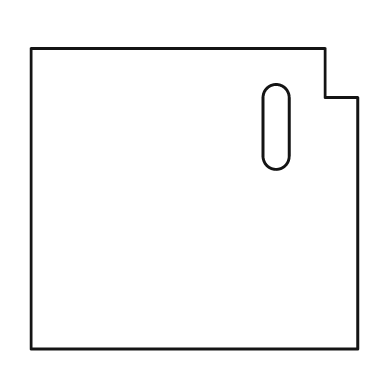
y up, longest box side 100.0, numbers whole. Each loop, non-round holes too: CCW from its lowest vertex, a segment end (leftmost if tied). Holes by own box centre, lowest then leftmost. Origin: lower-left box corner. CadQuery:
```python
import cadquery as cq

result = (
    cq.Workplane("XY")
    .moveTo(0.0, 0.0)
    .lineTo(100.0, 0.0)
    .lineTo(100.0, 77.0)
    .lineTo(90.0, 77.0)
    .lineTo(90.0, 92.0)
    .lineTo(0.0, 92.0)
    .close()
    .moveTo(71.0, 59.0)
    .threePointArc((75.0, 55.0), (79.0, 59.0))
    .lineTo(79.0, 77.0)
    .threePointArc((75.0, 81.0), (71.0, 77.0))
    .close()
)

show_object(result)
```